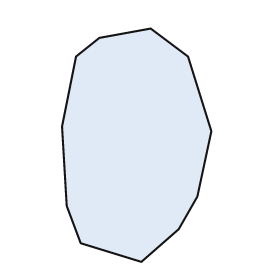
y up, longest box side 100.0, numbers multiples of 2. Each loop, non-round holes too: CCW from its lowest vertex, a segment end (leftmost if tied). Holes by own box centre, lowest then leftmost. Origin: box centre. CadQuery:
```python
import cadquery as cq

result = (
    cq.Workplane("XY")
    .moveTo(2.0, -50.0)
    .lineTo(18.0, -36.0)
    .lineTo(26.0, -22.0)
    .lineTo(32.0, 6.0)
    .lineTo(22.0, 38.0)
    .lineTo(6.0, 50.0)
    .lineTo(-16.0, 46.0)
    .lineTo(-26.0, 38.0)
    .lineTo(-32.0, 8.0)
    .lineTo(-30.0, -26.0)
    .lineTo(-24.0, -42.0)
    .close()
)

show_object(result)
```